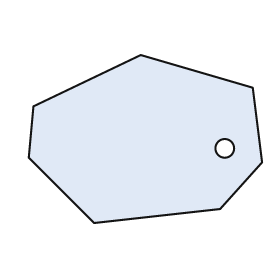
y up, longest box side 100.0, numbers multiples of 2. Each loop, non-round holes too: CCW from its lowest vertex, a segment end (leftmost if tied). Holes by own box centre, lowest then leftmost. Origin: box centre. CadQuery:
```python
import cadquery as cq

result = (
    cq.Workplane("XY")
    .moveTo(-22.0, -36.0)
    .lineTo(32.0, -30.0)
    .lineTo(50.0, -10.0)
    .lineTo(46.0, 22.0)
    .lineTo(-2.0, 36.0)
    .lineTo(-48.0, 14.0)
    .lineTo(-50.0, -8.0)
    .close()
    .moveTo(34.0, -4.0)
    .circle(4.0)
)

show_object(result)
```